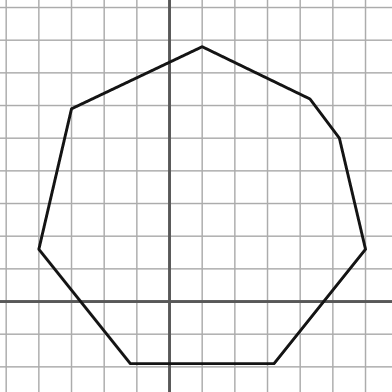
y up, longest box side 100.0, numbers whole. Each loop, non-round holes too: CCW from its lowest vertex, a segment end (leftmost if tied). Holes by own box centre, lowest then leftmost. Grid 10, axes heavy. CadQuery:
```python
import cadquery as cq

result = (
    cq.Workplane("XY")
    .moveTo(-12.0, -19.0)
    .lineTo(32.0, -19.0)
    .lineTo(60.0, 16.0)
    .lineTo(52.0, 50.0)
    .lineTo(43.0, 62.0)
    .lineTo(10.0, 78.0)
    .lineTo(-30.0, 59.0)
    .lineTo(-40.0, 16.0)
    .close()
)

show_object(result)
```